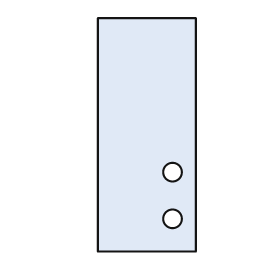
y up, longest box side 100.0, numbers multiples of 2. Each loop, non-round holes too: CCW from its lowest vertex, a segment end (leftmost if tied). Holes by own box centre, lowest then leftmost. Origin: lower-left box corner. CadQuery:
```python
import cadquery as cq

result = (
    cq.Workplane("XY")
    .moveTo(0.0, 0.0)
    .lineTo(42.0, 0.0)
    .lineTo(42.0, 100.0)
    .lineTo(0.0, 100.0)
    .close()
    .moveTo(32.0, 14.0)
    .circle(4.0)
    .moveTo(32.0, 34.0)
    .circle(4.0)
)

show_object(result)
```